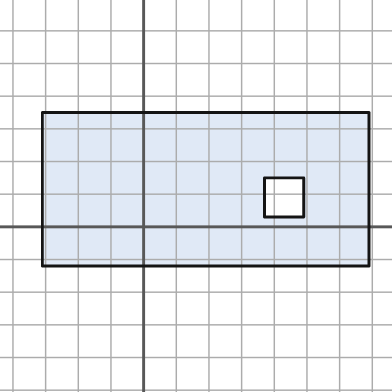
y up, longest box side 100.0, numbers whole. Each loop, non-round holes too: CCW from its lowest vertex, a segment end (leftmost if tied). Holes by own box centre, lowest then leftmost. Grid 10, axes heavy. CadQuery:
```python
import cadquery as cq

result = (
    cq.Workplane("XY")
    .moveTo(-31.0, -12.0)
    .lineTo(69.0, -12.0)
    .lineTo(69.0, 35.0)
    .lineTo(-31.0, 35.0)
    .close()
    .moveTo(37.0, 3.0)
    .lineTo(49.0, 3.0)
    .lineTo(49.0, 15.0)
    .lineTo(37.0, 15.0)
    .close()
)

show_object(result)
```